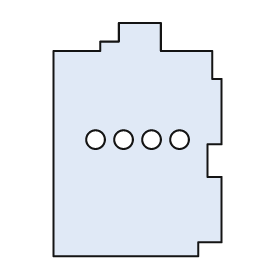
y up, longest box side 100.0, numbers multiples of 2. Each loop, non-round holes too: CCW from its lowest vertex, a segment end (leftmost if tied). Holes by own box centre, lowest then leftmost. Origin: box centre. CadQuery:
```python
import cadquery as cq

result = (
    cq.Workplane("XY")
    .moveTo(-36.0, -50.0)
    .lineTo(26.0, -50.0)
    .lineTo(26.0, -44.0)
    .lineTo(36.0, -44.0)
    .lineTo(36.0, -16.0)
    .lineTo(30.0, -16.0)
    .lineTo(30.0, -2.0)
    .lineTo(36.0, -2.0)
    .lineTo(36.0, 26.0)
    .lineTo(32.0, 26.0)
    .lineTo(32.0, 38.0)
    .lineTo(10.0, 38.0)
    .lineTo(10.0, 50.0)
    .lineTo(-8.0, 50.0)
    .lineTo(-8.0, 42.0)
    .lineTo(-16.0, 42.0)
    .lineTo(-16.0, 38.0)
    .lineTo(-36.0, 38.0)
    .close()
    .moveTo(-18.0, 0.0)
    .circle(4.0)
    .moveTo(-6.0, 0.0)
    .circle(4.0)
    .moveTo(6.0, 0.0)
    .circle(4.0)
    .moveTo(18.0, 0.0)
    .circle(4.0)
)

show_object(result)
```